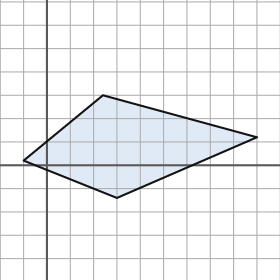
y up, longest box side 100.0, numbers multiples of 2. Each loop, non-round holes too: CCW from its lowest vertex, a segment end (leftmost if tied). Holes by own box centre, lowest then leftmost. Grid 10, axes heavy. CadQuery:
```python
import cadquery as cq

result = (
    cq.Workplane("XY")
    .moveTo(30.0, -14.0)
    .lineTo(90.0, 12.0)
    .lineTo(24.0, 30.0)
    .lineTo(-10.0, 2.0)
    .close()
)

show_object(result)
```